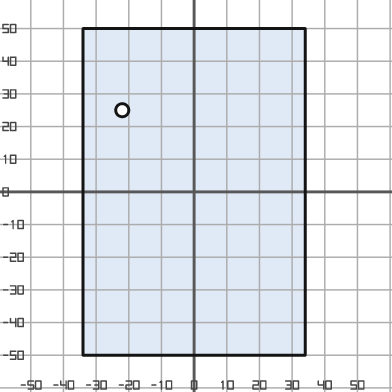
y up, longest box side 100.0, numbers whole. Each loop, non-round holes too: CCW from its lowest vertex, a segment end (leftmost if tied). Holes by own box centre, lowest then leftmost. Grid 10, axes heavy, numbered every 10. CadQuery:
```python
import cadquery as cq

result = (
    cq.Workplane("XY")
    .moveTo(-34.0, -50.0)
    .lineTo(34.0, -50.0)
    .lineTo(34.0, 50.0)
    .lineTo(-34.0, 50.0)
    .close()
    .moveTo(-22.0, 25.0)
    .circle(2.0)
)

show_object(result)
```